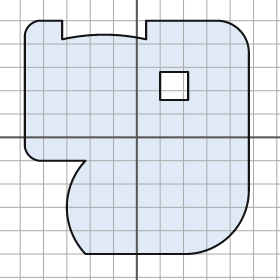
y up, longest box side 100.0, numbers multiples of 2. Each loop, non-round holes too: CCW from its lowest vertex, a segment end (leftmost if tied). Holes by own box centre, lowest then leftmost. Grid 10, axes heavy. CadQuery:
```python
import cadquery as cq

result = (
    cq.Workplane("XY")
    .moveTo(-22.0, -50.0)
    .lineTo(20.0, -50.0)
    .threePointArc((40.0, -42.0), (48.0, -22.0))
    .lineTo(48.0, 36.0)
    .threePointArc((44.0, 46.0), (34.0, 50.0))
    .lineTo(4.0, 50.0)
    .lineTo(4.0, 42.0)
    .threePointArc((-14.0, 44.0), (-32.0, 42.0))
    .lineTo(-32.0, 50.0)
    .lineTo(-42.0, 50.0)
    .threePointArc((-46.0, 48.0), (-48.0, 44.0))
    .lineTo(-48.0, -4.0)
    .threePointArc((-46.0, -8.0), (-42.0, -10.0))
    .lineTo(-22.0, -10.0)
    .threePointArc((-30.0, -30.0), (-22.0, -50.0))
    .close()
    .moveTo(10.0, 16.0)
    .lineTo(22.0, 16.0)
    .lineTo(22.0, 28.0)
    .lineTo(10.0, 28.0)
    .close()
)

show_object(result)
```